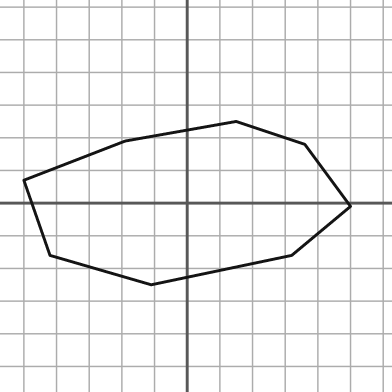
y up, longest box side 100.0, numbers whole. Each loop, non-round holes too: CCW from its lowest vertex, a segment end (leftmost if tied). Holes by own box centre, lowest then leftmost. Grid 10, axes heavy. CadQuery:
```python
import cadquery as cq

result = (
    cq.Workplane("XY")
    .moveTo(-11.0, -25.0)
    .lineTo(32.0, -16.0)
    .lineTo(50.0, -1.0)
    .lineTo(36.0, 18.0)
    .lineTo(15.0, 25.0)
    .lineTo(-19.0, 19.0)
    .lineTo(-50.0, 7.0)
    .lineTo(-42.0, -16.0)
    .close()
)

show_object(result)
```